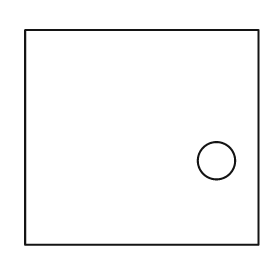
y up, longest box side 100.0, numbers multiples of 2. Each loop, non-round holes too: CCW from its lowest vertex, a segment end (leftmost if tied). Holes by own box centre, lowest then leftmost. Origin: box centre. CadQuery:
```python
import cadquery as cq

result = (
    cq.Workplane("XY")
    .moveTo(-50.0, -46.0)
    .lineTo(50.0, -46.0)
    .lineTo(50.0, 46.0)
    .lineTo(-50.0, 46.0)
    .close()
    .moveTo(32.0, -10.0)
    .circle(8.0)
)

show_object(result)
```